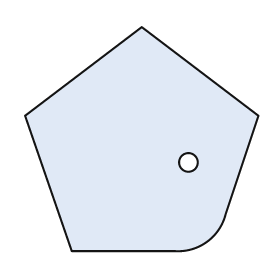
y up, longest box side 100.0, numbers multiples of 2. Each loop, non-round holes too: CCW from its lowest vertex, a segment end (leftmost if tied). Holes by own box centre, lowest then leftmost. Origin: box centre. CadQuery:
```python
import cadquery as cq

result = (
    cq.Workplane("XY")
    .moveTo(-30.0, -48.0)
    .lineTo(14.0, -48.0)
    .threePointArc((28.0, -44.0), (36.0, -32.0))
    .lineTo(50.0, 10.0)
    .lineTo(0.0, 48.0)
    .lineTo(-50.0, 10.0)
    .close()
    .moveTo(20.0, -10.0)
    .circle(4.0)
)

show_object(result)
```